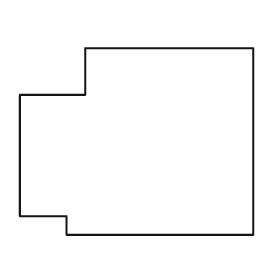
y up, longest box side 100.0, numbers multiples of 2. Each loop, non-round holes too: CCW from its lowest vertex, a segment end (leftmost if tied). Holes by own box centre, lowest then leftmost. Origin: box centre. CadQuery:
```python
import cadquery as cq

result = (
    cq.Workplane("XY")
    .moveTo(-30.0, -40.0)
    .lineTo(50.0, -40.0)
    .lineTo(50.0, 40.0)
    .lineTo(-22.0, 40.0)
    .lineTo(-22.0, 20.0)
    .lineTo(-50.0, 20.0)
    .lineTo(-50.0, -32.0)
    .lineTo(-30.0, -32.0)
    .close()
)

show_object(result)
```